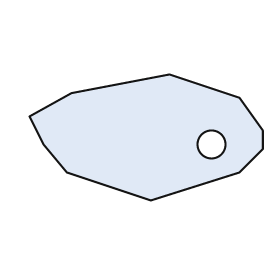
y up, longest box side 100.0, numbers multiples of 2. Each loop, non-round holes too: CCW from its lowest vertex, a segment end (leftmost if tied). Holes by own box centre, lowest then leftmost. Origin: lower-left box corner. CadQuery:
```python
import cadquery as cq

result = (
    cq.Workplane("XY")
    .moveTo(52.0, 0.0)
    .lineTo(90.0, 12.0)
    .lineTo(100.0, 22.0)
    .lineTo(100.0, 30.0)
    .lineTo(90.0, 44.0)
    .lineTo(60.0, 54.0)
    .lineTo(18.0, 46.0)
    .lineTo(0.0, 36.0)
    .lineTo(6.0, 24.0)
    .lineTo(16.0, 12.0)
    .close()
    .moveTo(78.0, 24.0)
    .circle(6.0)
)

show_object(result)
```